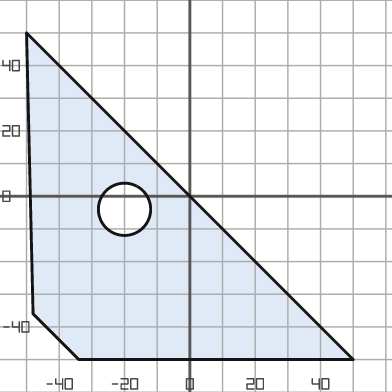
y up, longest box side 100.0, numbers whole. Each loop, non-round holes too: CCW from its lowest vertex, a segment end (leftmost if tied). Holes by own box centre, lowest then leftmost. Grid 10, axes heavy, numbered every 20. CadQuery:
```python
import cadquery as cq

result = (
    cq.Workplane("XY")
    .moveTo(-34.0, -50.0)
    .lineTo(50.0, -50.0)
    .lineTo(-50.0, 50.0)
    .lineTo(-48.0, -36.0)
    .close()
    .moveTo(-20.0, -4.0)
    .circle(8.0)
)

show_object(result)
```